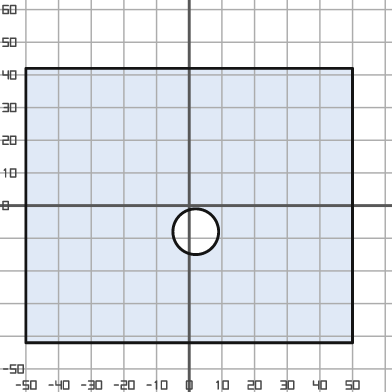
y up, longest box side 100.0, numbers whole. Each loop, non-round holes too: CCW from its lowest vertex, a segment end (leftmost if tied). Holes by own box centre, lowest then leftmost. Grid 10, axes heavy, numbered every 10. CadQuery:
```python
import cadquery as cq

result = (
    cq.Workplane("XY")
    .moveTo(-50.0, -42.0)
    .lineTo(50.0, -42.0)
    .lineTo(50.0, 42.0)
    .lineTo(-50.0, 42.0)
    .close()
    .moveTo(2.0, -8.0)
    .circle(7.0)
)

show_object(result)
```